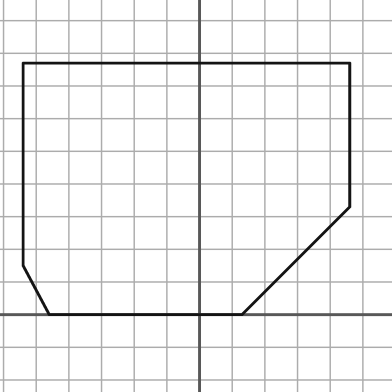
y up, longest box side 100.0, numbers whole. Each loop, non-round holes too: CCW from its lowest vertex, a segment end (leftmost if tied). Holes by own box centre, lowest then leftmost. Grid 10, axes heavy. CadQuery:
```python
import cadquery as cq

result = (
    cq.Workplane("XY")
    .moveTo(-46.0, 0.0)
    .lineTo(13.0, 0.0)
    .lineTo(46.0, 33.0)
    .lineTo(46.0, 77.0)
    .lineTo(-54.0, 77.0)
    .lineTo(-54.0, 15.0)
    .close()
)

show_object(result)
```